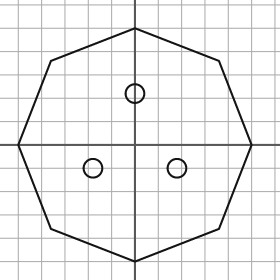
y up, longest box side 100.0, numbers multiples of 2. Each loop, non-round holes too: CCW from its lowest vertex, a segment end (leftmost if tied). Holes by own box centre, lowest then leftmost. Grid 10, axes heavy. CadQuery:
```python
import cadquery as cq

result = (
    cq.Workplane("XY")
    .moveTo(0.0, -50.0)
    .lineTo(36.0, -36.0)
    .lineTo(50.0, 0.0)
    .lineTo(36.0, 36.0)
    .lineTo(0.0, 50.0)
    .lineTo(-36.0, 36.0)
    .lineTo(-50.0, 0.0)
    .lineTo(-36.0, -36.0)
    .close()
    .moveTo(-18.0, -10.0)
    .circle(4.0)
    .moveTo(18.0, -10.0)
    .circle(4.0)
    .moveTo(0.0, 22.0)
    .circle(4.0)
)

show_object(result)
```